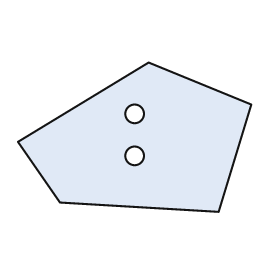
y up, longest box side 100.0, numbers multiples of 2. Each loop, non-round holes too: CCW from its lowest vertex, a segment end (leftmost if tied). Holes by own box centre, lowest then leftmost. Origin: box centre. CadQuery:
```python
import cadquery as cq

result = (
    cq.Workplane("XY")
    .moveTo(36.0, -32.0)
    .lineTo(50.0, 14.0)
    .lineTo(6.0, 32.0)
    .lineTo(-50.0, -2.0)
    .lineTo(-32.0, -28.0)
    .close()
    .moveTo(0.0, -8.0)
    .circle(4.0)
    .moveTo(0.0, 10.0)
    .circle(4.0)
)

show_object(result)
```